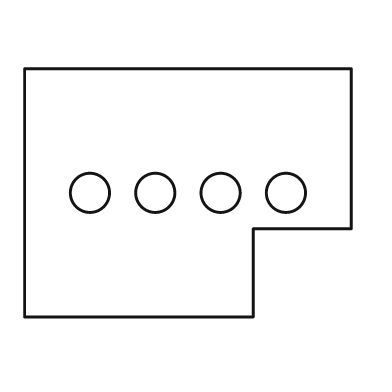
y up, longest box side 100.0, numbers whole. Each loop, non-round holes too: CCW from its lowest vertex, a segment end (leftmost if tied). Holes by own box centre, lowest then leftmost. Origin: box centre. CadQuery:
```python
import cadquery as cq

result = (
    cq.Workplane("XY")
    .moveTo(-50.0, -38.0)
    .lineTo(20.0, -38.0)
    .lineTo(20.0, -11.0)
    .lineTo(50.0, -11.0)
    .lineTo(50.0, 38.0)
    .lineTo(-50.0, 38.0)
    .close()
    .moveTo(-30.0, 0.0)
    .circle(6.0)
    .moveTo(-10.0, 0.0)
    .circle(6.0)
    .moveTo(10.0, 0.0)
    .circle(6.0)
    .moveTo(30.0, 0.0)
    .circle(6.0)
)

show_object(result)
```